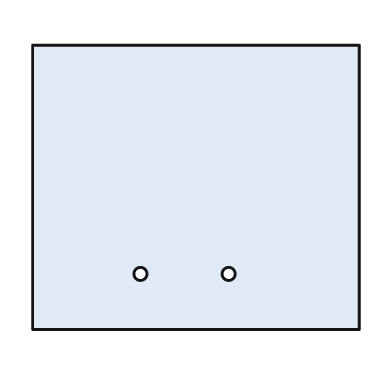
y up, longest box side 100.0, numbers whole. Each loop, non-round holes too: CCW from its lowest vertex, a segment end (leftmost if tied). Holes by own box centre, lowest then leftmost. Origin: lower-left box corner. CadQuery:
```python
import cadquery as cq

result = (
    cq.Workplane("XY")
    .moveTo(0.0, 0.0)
    .lineTo(100.0, 0.0)
    .lineTo(100.0, 87.0)
    .lineTo(0.0, 87.0)
    .close()
    .moveTo(33.0, 17.0)
    .circle(2.0)
    .moveTo(60.0, 17.0)
    .circle(2.0)
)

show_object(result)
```